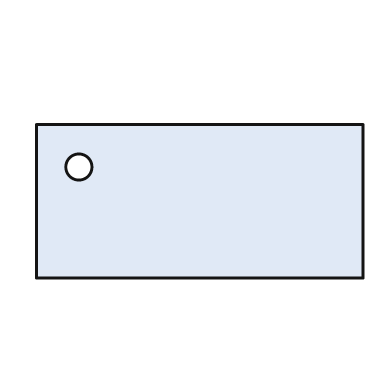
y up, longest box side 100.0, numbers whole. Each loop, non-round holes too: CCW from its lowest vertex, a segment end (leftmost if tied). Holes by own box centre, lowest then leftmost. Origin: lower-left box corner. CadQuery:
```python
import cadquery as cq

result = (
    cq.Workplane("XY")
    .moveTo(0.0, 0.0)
    .lineTo(100.0, 0.0)
    .lineTo(100.0, 47.0)
    .lineTo(0.0, 47.0)
    .close()
    .moveTo(13.0, 34.0)
    .circle(4.0)
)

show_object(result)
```